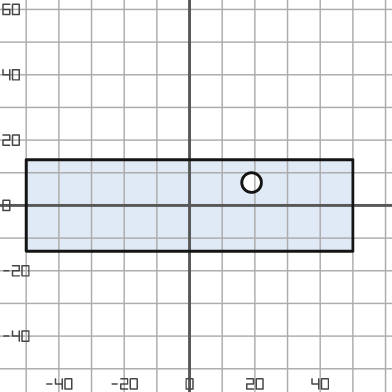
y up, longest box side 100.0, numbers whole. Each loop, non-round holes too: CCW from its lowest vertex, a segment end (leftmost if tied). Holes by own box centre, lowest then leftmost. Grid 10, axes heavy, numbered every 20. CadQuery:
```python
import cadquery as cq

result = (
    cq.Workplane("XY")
    .moveTo(-50.0, -14.0)
    .lineTo(50.0, -14.0)
    .lineTo(50.0, 14.0)
    .lineTo(-50.0, 14.0)
    .close()
    .moveTo(19.0, 7.0)
    .circle(3.0)
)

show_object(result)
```